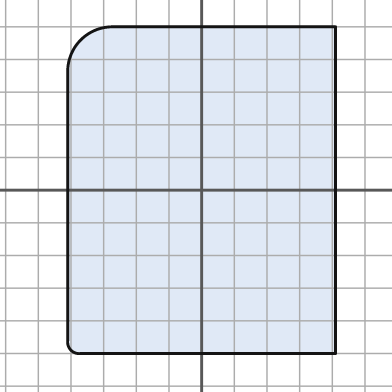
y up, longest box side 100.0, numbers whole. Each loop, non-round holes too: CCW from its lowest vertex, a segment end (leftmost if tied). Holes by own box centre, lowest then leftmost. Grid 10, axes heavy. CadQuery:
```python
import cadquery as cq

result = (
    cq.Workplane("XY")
    .moveTo(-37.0, -50.0)
    .lineTo(41.0, -50.0)
    .lineTo(41.0, 50.0)
    .lineTo(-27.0, 50.0)
    .threePointArc((-37.0, 46.0), (-41.0, 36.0))
    .lineTo(-41.0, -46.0)
    .threePointArc((-40.0, -49.0), (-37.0, -50.0))
    .close()
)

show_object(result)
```